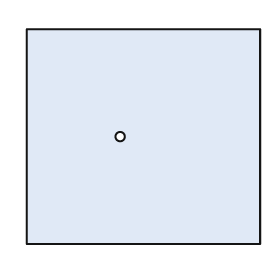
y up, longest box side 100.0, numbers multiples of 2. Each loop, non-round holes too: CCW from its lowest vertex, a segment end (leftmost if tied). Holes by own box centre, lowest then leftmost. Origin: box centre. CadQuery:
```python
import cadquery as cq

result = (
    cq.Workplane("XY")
    .moveTo(-50.0, -46.0)
    .lineTo(50.0, -46.0)
    .lineTo(50.0, 46.0)
    .lineTo(-50.0, 46.0)
    .close()
    .moveTo(-10.0, 0.0)
    .circle(2.0)
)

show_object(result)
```